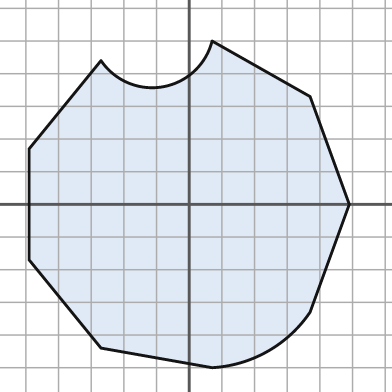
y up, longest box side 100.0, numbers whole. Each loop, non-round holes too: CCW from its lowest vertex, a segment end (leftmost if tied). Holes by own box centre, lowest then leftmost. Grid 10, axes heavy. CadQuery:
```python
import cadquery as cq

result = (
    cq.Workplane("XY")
    .moveTo(7.0, -50.0)
    .threePointArc((24.0, -45.0), (37.0, -33.0))
    .lineTo(49.0, 0.0)
    .lineTo(37.0, 33.0)
    .lineTo(7.0, 50.0)
    .threePointArc((-8.0, 36.0), (-27.0, 44.0))
    .lineTo(-49.0, 17.0)
    .lineTo(-49.0, -17.0)
    .lineTo(-27.0, -44.0)
    .close()
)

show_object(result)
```